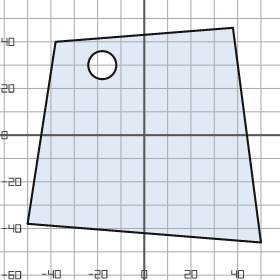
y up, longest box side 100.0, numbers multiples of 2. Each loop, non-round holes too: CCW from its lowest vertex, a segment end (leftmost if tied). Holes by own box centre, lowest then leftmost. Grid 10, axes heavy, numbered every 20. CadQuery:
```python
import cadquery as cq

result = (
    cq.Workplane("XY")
    .moveTo(50.0, -46.0)
    .lineTo(38.0, 46.0)
    .lineTo(-38.0, 40.0)
    .lineTo(-50.0, -38.0)
    .close()
    .moveTo(-18.0, 30.0)
    .circle(6.0)
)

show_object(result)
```